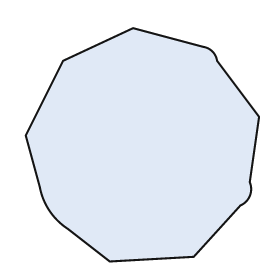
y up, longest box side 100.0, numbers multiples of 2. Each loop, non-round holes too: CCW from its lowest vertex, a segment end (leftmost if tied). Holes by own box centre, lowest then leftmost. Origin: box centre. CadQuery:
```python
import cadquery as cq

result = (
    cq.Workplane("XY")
    .moveTo(-14.0, -50.0)
    .lineTo(22.0, -48.0)
    .lineTo(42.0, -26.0)
    .threePointArc((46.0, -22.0), (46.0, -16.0))
    .lineTo(50.0, 12.0)
    .lineTo(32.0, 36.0)
    .threePointArc((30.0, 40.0), (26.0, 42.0))
    .lineTo(-4.0, 50.0)
    .lineTo(-34.0, 36.0)
    .lineTo(-50.0, 4.0)
    .lineTo(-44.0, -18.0)
    .threePointArc((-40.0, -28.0), (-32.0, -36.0))
    .close()
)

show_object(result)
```